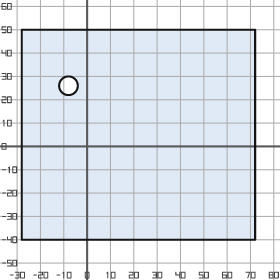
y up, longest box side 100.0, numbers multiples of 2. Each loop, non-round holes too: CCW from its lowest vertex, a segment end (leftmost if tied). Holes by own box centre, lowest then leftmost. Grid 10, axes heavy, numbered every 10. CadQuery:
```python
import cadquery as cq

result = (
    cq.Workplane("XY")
    .moveTo(-28.0, -40.0)
    .lineTo(72.0, -40.0)
    .lineTo(72.0, 50.0)
    .lineTo(-28.0, 50.0)
    .close()
    .moveTo(-8.0, 26.0)
    .circle(4.0)
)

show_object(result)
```